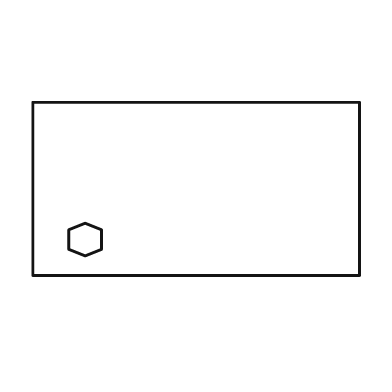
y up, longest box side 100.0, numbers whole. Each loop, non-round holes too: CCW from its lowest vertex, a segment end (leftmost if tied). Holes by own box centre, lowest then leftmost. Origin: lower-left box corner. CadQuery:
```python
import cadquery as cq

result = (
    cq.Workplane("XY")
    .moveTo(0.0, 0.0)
    .lineTo(100.0, 0.0)
    .lineTo(100.0, 53.0)
    .lineTo(0.0, 53.0)
    .close()
    .moveTo(16.0, 6.0)
    .lineTo(21.0, 8.0)
    .lineTo(21.0, 14.0)
    .lineTo(16.0, 16.0)
    .lineTo(11.0, 14.0)
    .lineTo(11.0, 8.0)
    .close()
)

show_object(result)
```